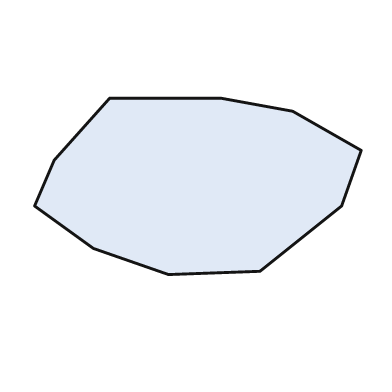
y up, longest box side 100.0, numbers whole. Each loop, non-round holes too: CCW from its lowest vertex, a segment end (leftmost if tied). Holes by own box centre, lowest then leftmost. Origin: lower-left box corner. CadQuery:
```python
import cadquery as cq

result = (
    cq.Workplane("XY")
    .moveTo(41.0, 0.0)
    .lineTo(69.0, 1.0)
    .lineTo(94.0, 21.0)
    .lineTo(100.0, 38.0)
    .lineTo(79.0, 50.0)
    .lineTo(57.0, 54.0)
    .lineTo(23.0, 54.0)
    .lineTo(6.0, 35.0)
    .lineTo(0.0, 21.0)
    .lineTo(18.0, 8.0)
    .close()
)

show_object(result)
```